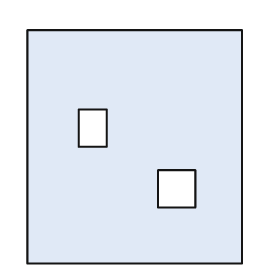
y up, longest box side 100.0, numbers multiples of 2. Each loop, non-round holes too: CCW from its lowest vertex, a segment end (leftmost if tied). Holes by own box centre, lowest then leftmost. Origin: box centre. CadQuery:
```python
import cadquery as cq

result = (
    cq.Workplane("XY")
    .moveTo(-46.0, -50.0)
    .lineTo(46.0, -50.0)
    .lineTo(46.0, 50.0)
    .lineTo(-46.0, 50.0)
    .close()
    .moveTo(10.0, -26.0)
    .lineTo(26.0, -26.0)
    .lineTo(26.0, -10.0)
    .lineTo(10.0, -10.0)
    .close()
    .moveTo(-24.0, 0.0)
    .lineTo(-12.0, 0.0)
    .lineTo(-12.0, 16.0)
    .lineTo(-24.0, 16.0)
    .close()
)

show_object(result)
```